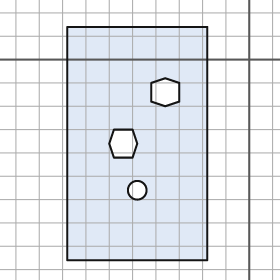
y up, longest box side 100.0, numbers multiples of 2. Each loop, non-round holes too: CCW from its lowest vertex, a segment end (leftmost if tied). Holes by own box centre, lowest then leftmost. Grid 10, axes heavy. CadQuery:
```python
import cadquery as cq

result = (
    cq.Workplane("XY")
    .moveTo(-78.0, -86.0)
    .lineTo(-18.0, -86.0)
    .lineTo(-18.0, 14.0)
    .lineTo(-78.0, 14.0)
    .close()
    .moveTo(-48.0, -56.0)
    .circle(4.0)
    .moveTo(-58.0, -42.0)
    .lineTo(-50.0, -42.0)
    .lineTo(-48.0, -36.0)
    .lineTo(-50.0, -30.0)
    .lineTo(-58.0, -30.0)
    .lineTo(-60.0, -36.0)
    .close()
    .moveTo(-36.0, -20.0)
    .lineTo(-30.0, -18.0)
    .lineTo(-30.0, -10.0)
    .lineTo(-36.0, -8.0)
    .lineTo(-42.0, -10.0)
    .lineTo(-42.0, -18.0)
    .close()
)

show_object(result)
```